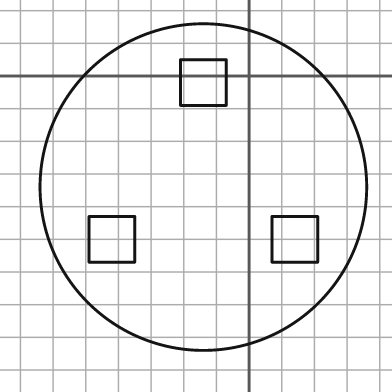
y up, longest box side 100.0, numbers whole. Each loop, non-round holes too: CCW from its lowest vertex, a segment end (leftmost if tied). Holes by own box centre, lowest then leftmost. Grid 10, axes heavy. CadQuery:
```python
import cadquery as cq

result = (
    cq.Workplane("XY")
    .moveTo(-14.0, -34.0)
    .circle(50.0)
    .moveTo(-49.0, -57.0)
    .lineTo(-35.0, -57.0)
    .lineTo(-35.0, -43.0)
    .lineTo(-49.0, -43.0)
    .close()
    .moveTo(7.0, -57.0)
    .lineTo(21.0, -57.0)
    .lineTo(21.0, -43.0)
    .lineTo(7.0, -43.0)
    .close()
    .moveTo(-21.0, -9.0)
    .lineTo(-7.0, -9.0)
    .lineTo(-7.0, 5.0)
    .lineTo(-21.0, 5.0)
    .close()
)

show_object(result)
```